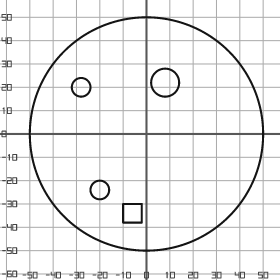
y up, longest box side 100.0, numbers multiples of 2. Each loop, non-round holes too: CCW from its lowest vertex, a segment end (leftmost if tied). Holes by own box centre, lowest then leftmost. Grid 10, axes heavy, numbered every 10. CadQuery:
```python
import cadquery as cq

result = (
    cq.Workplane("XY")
    .moveTo(0.0, 0.0)
    .circle(50.0)
    .moveTo(-10.0, -38.0)
    .lineTo(-2.0, -38.0)
    .lineTo(-2.0, -30.0)
    .lineTo(-10.0, -30.0)
    .close()
    .moveTo(-20.0, -24.0)
    .circle(4.0)
    .moveTo(-28.0, 20.0)
    .circle(4.0)
    .moveTo(8.0, 22.0)
    .circle(6.0)
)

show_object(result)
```